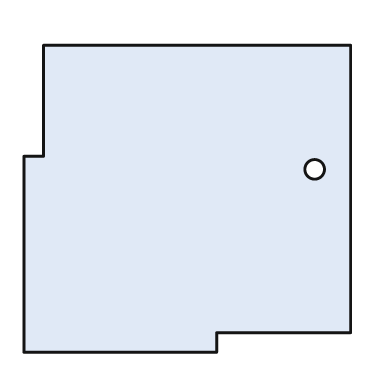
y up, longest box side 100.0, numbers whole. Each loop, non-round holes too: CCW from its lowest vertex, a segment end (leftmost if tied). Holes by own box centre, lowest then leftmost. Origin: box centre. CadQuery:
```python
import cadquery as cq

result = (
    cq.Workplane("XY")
    .moveTo(-50.0, -47.0)
    .lineTo(9.0, -47.0)
    .lineTo(9.0, -41.0)
    .lineTo(50.0, -41.0)
    .lineTo(50.0, 47.0)
    .lineTo(-44.0, 47.0)
    .lineTo(-44.0, 13.0)
    .lineTo(-50.0, 13.0)
    .close()
    .moveTo(39.0, 9.0)
    .circle(3.0)
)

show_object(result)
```